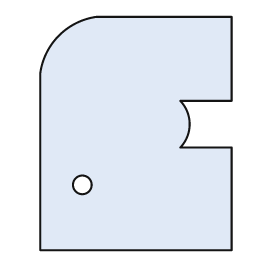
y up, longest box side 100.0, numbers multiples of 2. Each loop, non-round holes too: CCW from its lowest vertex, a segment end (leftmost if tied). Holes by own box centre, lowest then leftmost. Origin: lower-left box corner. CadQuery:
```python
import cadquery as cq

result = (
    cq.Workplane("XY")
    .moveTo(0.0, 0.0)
    .lineTo(82.0, 0.0)
    .lineTo(82.0, 44.0)
    .lineTo(60.0, 44.0)
    .threePointArc((64.0, 54.0), (60.0, 64.0))
    .lineTo(82.0, 64.0)
    .lineTo(82.0, 100.0)
    .lineTo(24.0, 100.0)
    .threePointArc((8.0, 92.0), (0.0, 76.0))
    .close()
    .moveTo(18.0, 28.0)
    .circle(4.0)
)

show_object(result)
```